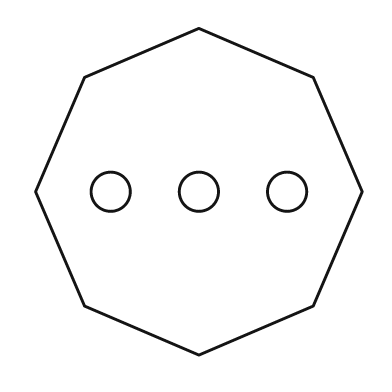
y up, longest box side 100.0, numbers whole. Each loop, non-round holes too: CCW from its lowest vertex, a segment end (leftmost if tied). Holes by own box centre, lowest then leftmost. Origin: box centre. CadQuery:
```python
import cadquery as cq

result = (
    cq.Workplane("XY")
    .moveTo(0.0, -50.0)
    .lineTo(35.0, -35.0)
    .lineTo(50.0, 0.0)
    .lineTo(35.0, 35.0)
    .lineTo(0.0, 50.0)
    .lineTo(-35.0, 35.0)
    .lineTo(-50.0, 0.0)
    .lineTo(-35.0, -35.0)
    .close()
    .moveTo(-27.0, 0.0)
    .circle(6.0)
    .moveTo(0.0, 0.0)
    .circle(6.0)
    .moveTo(27.0, 0.0)
    .circle(6.0)
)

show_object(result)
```